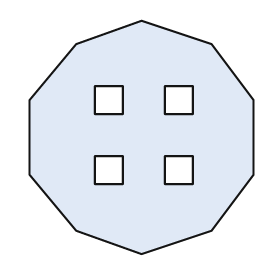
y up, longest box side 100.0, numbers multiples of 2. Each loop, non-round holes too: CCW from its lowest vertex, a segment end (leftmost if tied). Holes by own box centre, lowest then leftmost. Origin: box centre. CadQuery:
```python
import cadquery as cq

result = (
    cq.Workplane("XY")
    .moveTo(0.0, -50.0)
    .lineTo(30.0, -40.0)
    .lineTo(48.0, -16.0)
    .lineTo(48.0, 16.0)
    .lineTo(30.0, 40.0)
    .lineTo(0.0, 50.0)
    .lineTo(-28.0, 40.0)
    .lineTo(-48.0, 16.0)
    .lineTo(-48.0, -16.0)
    .lineTo(-28.0, -40.0)
    .close()
    .moveTo(-20.0, -20.0)
    .lineTo(-8.0, -20.0)
    .lineTo(-8.0, -8.0)
    .lineTo(-20.0, -8.0)
    .close()
    .moveTo(10.0, -20.0)
    .lineTo(22.0, -20.0)
    .lineTo(22.0, -8.0)
    .lineTo(10.0, -8.0)
    .close()
    .moveTo(-20.0, 10.0)
    .lineTo(-8.0, 10.0)
    .lineTo(-8.0, 22.0)
    .lineTo(-20.0, 22.0)
    .close()
    .moveTo(10.0, 10.0)
    .lineTo(22.0, 10.0)
    .lineTo(22.0, 22.0)
    .lineTo(10.0, 22.0)
    .close()
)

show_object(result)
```